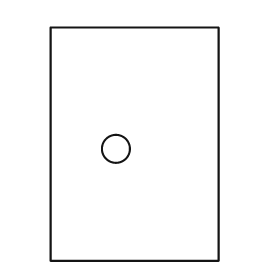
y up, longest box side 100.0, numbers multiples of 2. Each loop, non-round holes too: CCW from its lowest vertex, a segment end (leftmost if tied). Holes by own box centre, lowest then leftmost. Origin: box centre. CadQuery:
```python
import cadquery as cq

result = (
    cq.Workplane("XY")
    .moveTo(-36.0, -50.0)
    .lineTo(36.0, -50.0)
    .lineTo(36.0, 50.0)
    .lineTo(-36.0, 50.0)
    .close()
    .moveTo(-8.0, -2.0)
    .circle(6.0)
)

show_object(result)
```